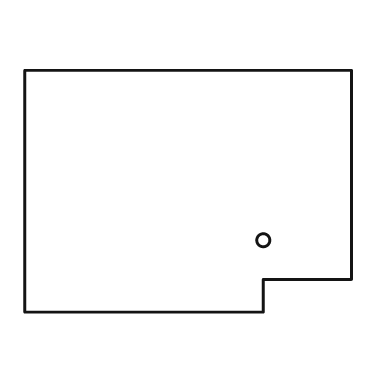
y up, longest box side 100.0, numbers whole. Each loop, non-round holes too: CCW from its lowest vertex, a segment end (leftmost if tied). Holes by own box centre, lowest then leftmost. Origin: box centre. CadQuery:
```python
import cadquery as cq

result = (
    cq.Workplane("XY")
    .moveTo(-50.0, -37.0)
    .lineTo(23.0, -37.0)
    .lineTo(23.0, -27.0)
    .lineTo(50.0, -27.0)
    .lineTo(50.0, 37.0)
    .lineTo(-50.0, 37.0)
    .close()
    .moveTo(23.0, -15.0)
    .circle(2.0)
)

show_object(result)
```